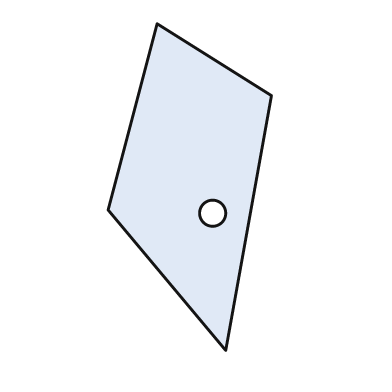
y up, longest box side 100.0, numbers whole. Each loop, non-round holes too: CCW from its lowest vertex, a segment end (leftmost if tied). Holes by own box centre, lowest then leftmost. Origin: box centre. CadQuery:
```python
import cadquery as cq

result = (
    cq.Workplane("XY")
    .moveTo(11.0, -50.0)
    .lineTo(25.0, 28.0)
    .lineTo(-10.0, 50.0)
    .lineTo(-25.0, -7.0)
    .close()
    .moveTo(7.0, -8.0)
    .circle(4.0)
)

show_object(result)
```